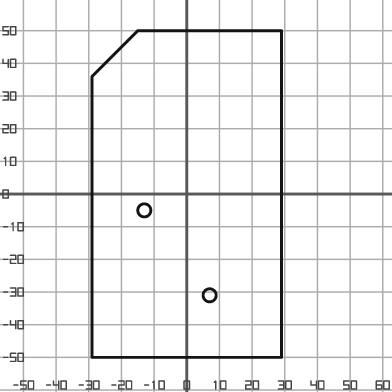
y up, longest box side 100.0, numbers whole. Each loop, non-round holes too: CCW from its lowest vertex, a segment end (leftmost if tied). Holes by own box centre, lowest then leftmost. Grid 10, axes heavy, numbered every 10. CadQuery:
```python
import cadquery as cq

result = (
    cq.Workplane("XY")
    .moveTo(-29.0, -50.0)
    .lineTo(29.0, -50.0)
    .lineTo(29.0, 50.0)
    .lineTo(-15.0, 50.0)
    .lineTo(-29.0, 36.0)
    .close()
    .moveTo(7.0, -31.0)
    .circle(2.0)
    .moveTo(-13.0, -5.0)
    .circle(2.0)
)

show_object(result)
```